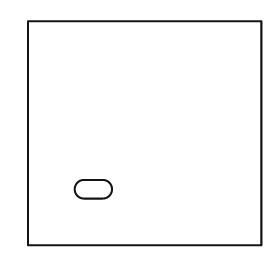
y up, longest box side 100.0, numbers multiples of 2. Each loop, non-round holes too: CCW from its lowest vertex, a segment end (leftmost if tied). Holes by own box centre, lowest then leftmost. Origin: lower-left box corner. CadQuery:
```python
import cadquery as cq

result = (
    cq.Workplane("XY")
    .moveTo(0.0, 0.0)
    .lineTo(100.0, 0.0)
    .lineTo(100.0, 96.0)
    .lineTo(0.0, 96.0)
    .close()
    .moveTo(24.0, 20.0)
    .lineTo(32.0, 20.0)
    .threePointArc((36.0, 24.0), (32.0, 28.0))
    .lineTo(24.0, 28.0)
    .threePointArc((20.0, 24.0), (24.0, 20.0))
    .close()
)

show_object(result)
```